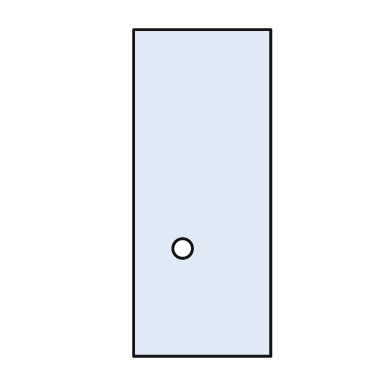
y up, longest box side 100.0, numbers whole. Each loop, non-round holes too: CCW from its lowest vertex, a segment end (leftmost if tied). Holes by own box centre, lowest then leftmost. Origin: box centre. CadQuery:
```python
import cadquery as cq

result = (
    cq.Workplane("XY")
    .moveTo(-21.0, -50.0)
    .lineTo(21.0, -50.0)
    .lineTo(21.0, 50.0)
    .lineTo(-21.0, 50.0)
    .close()
    .moveTo(-6.0, -17.0)
    .circle(3.0)
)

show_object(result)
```